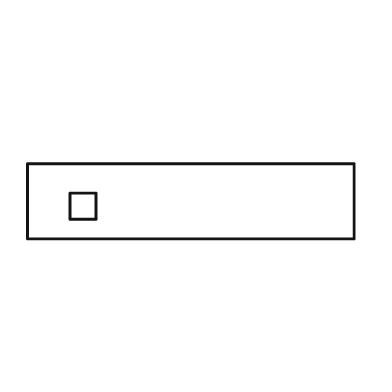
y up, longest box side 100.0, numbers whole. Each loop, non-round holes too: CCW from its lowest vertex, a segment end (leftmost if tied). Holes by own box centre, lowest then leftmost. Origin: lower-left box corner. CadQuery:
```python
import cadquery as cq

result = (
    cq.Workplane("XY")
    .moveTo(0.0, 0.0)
    .lineTo(100.0, 0.0)
    .lineTo(100.0, 23.0)
    .lineTo(0.0, 23.0)
    .close()
    .moveTo(13.0, 6.0)
    .lineTo(21.0, 6.0)
    .lineTo(21.0, 14.0)
    .lineTo(13.0, 14.0)
    .close()
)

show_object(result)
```